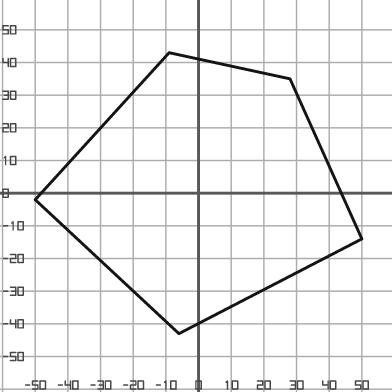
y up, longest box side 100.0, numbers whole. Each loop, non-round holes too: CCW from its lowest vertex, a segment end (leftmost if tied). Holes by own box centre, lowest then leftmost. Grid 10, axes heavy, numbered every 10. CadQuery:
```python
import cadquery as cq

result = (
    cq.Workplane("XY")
    .moveTo(-6.0, -43.0)
    .lineTo(50.0, -14.0)
    .lineTo(28.0, 35.0)
    .lineTo(-9.0, 43.0)
    .lineTo(-50.0, -2.0)
    .close()
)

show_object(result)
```